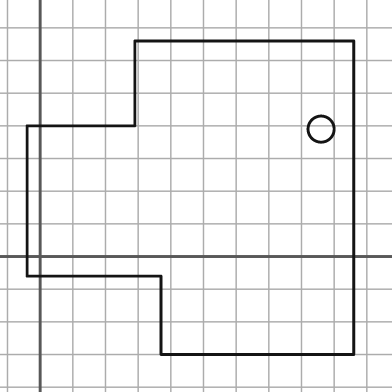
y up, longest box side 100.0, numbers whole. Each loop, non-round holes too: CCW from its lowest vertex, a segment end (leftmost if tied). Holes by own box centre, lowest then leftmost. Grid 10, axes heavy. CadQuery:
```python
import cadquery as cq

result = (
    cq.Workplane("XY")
    .moveTo(37.0, -30.0)
    .lineTo(96.0, -30.0)
    .lineTo(96.0, 66.0)
    .lineTo(29.0, 66.0)
    .lineTo(29.0, 40.0)
    .lineTo(-4.0, 40.0)
    .lineTo(-4.0, -6.0)
    .lineTo(37.0, -6.0)
    .close()
    .moveTo(86.0, 39.0)
    .circle(4.0)
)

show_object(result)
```